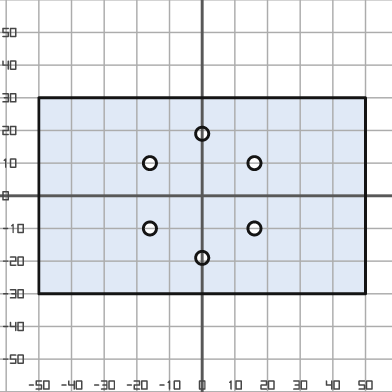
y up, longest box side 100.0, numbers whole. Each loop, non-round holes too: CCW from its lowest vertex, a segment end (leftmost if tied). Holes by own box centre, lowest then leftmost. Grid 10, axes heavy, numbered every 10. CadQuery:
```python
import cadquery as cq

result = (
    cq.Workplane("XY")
    .moveTo(-50.0, -30.0)
    .lineTo(50.0, -30.0)
    .lineTo(50.0, 30.0)
    .lineTo(-50.0, 30.0)
    .close()
    .moveTo(0.0, -19.0)
    .circle(2.0)
    .moveTo(-16.0, -10.0)
    .circle(2.0)
    .moveTo(16.0, -10.0)
    .circle(2.0)
    .moveTo(-16.0, 10.0)
    .circle(2.0)
    .moveTo(16.0, 10.0)
    .circle(2.0)
    .moveTo(0.0, 19.0)
    .circle(2.0)
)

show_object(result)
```